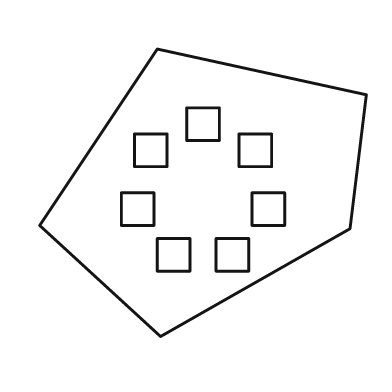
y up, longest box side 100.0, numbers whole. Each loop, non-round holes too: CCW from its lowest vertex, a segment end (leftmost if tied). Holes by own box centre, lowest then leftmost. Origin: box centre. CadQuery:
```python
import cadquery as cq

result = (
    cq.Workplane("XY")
    .moveTo(-13.0, -44.0)
    .lineTo(45.0, -11.0)
    .lineTo(50.0, 30.0)
    .lineTo(-14.0, 44.0)
    .lineTo(-50.0, -10.0)
    .close()
    .moveTo(-14.0, -24.0)
    .lineTo(-4.0, -24.0)
    .lineTo(-4.0, -14.0)
    .lineTo(-14.0, -14.0)
    .close()
    .moveTo(4.0, -24.0)
    .lineTo(14.0, -24.0)
    .lineTo(14.0, -14.0)
    .lineTo(4.0, -14.0)
    .close()
    .moveTo(-25.0, -10.0)
    .lineTo(-15.0, -10.0)
    .lineTo(-15.0, 0.0)
    .lineTo(-25.0, 0.0)
    .close()
    .moveTo(15.0, -10.0)
    .lineTo(25.0, -10.0)
    .lineTo(25.0, 0.0)
    .lineTo(15.0, 0.0)
    .close()
    .moveTo(-21.0, 8.0)
    .lineTo(-11.0, 8.0)
    .lineTo(-11.0, 18.0)
    .lineTo(-21.0, 18.0)
    .close()
    .moveTo(11.0, 8.0)
    .lineTo(21.0, 8.0)
    .lineTo(21.0, 18.0)
    .lineTo(11.0, 18.0)
    .close()
    .moveTo(-5.0, 16.0)
    .lineTo(5.0, 16.0)
    .lineTo(5.0, 26.0)
    .lineTo(-5.0, 26.0)
    .close()
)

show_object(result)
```